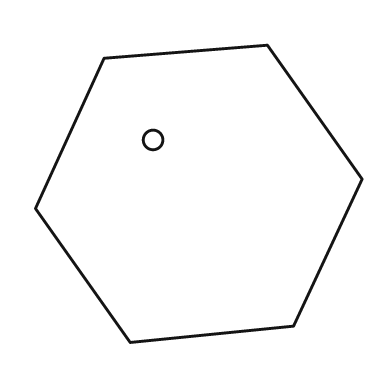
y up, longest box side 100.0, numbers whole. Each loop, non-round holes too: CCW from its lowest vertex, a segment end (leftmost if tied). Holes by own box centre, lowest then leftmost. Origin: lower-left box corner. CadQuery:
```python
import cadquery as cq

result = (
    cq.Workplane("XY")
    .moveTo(29.0, 0.0)
    .lineTo(79.0, 5.0)
    .lineTo(100.0, 50.0)
    .lineTo(71.0, 91.0)
    .lineTo(21.0, 87.0)
    .lineTo(0.0, 41.0)
    .close()
    .moveTo(36.0, 62.0)
    .circle(3.0)
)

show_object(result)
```